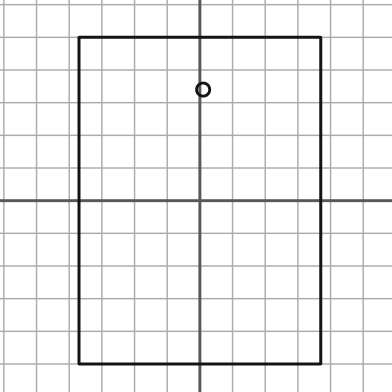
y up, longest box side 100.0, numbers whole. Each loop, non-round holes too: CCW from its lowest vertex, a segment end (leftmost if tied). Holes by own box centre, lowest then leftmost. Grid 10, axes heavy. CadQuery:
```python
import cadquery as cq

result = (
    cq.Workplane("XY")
    .moveTo(-37.0, -50.0)
    .lineTo(37.0, -50.0)
    .lineTo(37.0, 50.0)
    .lineTo(-37.0, 50.0)
    .close()
    .moveTo(1.0, 34.0)
    .circle(2.0)
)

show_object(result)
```